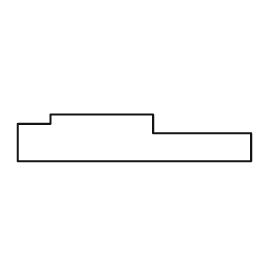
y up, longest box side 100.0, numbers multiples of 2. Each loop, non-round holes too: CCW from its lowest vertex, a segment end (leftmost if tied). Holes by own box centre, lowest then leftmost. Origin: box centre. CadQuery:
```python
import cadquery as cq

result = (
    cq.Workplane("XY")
    .moveTo(-50.0, -10.0)
    .lineTo(50.0, -10.0)
    .lineTo(50.0, 2.0)
    .lineTo(8.0, 2.0)
    .lineTo(8.0, 10.0)
    .lineTo(-36.0, 10.0)
    .lineTo(-36.0, 6.0)
    .lineTo(-50.0, 6.0)
    .close()
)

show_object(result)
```